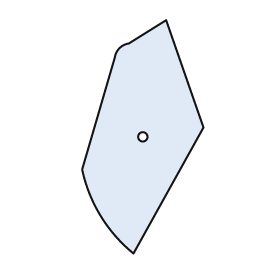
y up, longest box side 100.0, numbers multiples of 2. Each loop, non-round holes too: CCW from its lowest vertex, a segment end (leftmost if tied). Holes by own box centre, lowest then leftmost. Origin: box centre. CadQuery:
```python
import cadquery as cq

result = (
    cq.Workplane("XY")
    .moveTo(-4.0, -50.0)
    .lineTo(26.0, 4.0)
    .lineTo(10.0, 50.0)
    .lineTo(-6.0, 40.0)
    .threePointArc((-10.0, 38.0), (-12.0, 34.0))
    .lineTo(-26.0, -14.0)
    .threePointArc((-18.0, -34.0), (-4.0, -50.0))
    .close()
    .moveTo(0.0, 0.0)
    .circle(2.0)
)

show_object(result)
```